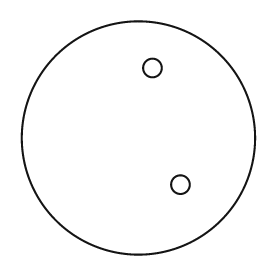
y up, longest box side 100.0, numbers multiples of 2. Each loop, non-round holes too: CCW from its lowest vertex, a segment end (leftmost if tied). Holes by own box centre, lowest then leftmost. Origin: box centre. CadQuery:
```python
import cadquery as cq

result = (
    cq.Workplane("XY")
    .moveTo(0.0, 0.0)
    .circle(50.0)
    .moveTo(18.0, -20.0)
    .circle(4.0)
    .moveTo(6.0, 30.0)
    .circle(4.0)
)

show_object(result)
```